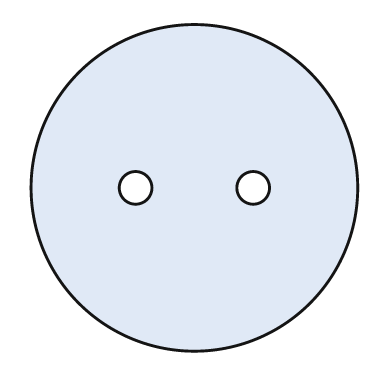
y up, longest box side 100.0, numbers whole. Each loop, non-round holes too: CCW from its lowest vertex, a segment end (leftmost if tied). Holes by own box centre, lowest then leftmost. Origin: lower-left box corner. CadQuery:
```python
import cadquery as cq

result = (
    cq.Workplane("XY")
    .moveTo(50.0, 50.0)
    .circle(50.0)
    .moveTo(32.0, 50.0)
    .circle(5.0)
    .moveTo(68.0, 50.0)
    .circle(5.0)
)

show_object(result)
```